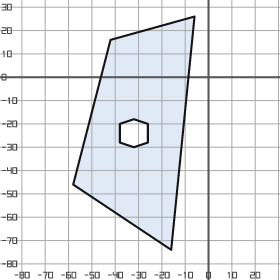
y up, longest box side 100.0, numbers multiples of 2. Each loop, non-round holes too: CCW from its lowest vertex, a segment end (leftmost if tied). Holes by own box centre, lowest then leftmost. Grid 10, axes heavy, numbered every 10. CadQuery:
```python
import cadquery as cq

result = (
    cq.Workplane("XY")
    .moveTo(-16.0, -74.0)
    .lineTo(-6.0, 26.0)
    .lineTo(-42.0, 16.0)
    .lineTo(-58.0, -46.0)
    .close()
    .moveTo(-32.0, -30.0)
    .lineTo(-26.0, -28.0)
    .lineTo(-26.0, -20.0)
    .lineTo(-32.0, -18.0)
    .lineTo(-38.0, -20.0)
    .lineTo(-38.0, -28.0)
    .close()
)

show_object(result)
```